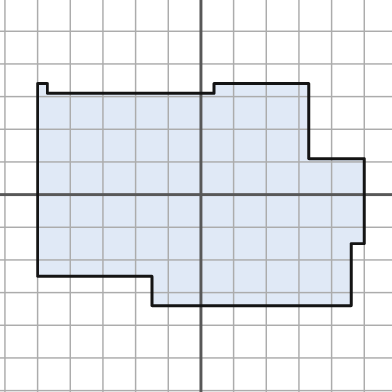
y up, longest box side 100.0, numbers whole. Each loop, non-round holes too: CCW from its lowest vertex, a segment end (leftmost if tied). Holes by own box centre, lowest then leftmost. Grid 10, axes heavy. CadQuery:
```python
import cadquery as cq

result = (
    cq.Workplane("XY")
    .moveTo(-15.0, -34.0)
    .lineTo(46.0, -34.0)
    .lineTo(46.0, -15.0)
    .lineTo(50.0, -15.0)
    .lineTo(50.0, 11.0)
    .lineTo(33.0, 11.0)
    .lineTo(33.0, 34.0)
    .lineTo(4.0, 34.0)
    .lineTo(4.0, 31.0)
    .lineTo(-47.0, 31.0)
    .lineTo(-47.0, 34.0)
    .lineTo(-50.0, 34.0)
    .lineTo(-50.0, -25.0)
    .lineTo(-15.0, -25.0)
    .close()
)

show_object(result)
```